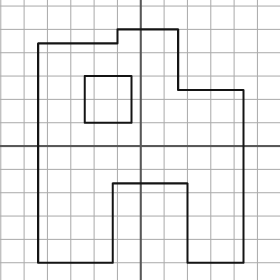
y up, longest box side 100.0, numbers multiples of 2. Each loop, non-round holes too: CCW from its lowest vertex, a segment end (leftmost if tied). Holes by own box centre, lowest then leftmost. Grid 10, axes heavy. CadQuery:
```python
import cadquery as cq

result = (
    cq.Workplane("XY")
    .moveTo(-44.0, -50.0)
    .lineTo(-12.0, -50.0)
    .lineTo(-12.0, -16.0)
    .lineTo(20.0, -16.0)
    .lineTo(20.0, -50.0)
    .lineTo(44.0, -50.0)
    .lineTo(44.0, 24.0)
    .lineTo(16.0, 24.0)
    .lineTo(16.0, 50.0)
    .lineTo(-10.0, 50.0)
    .lineTo(-10.0, 44.0)
    .lineTo(-44.0, 44.0)
    .close()
    .moveTo(-24.0, 10.0)
    .lineTo(-4.0, 10.0)
    .lineTo(-4.0, 30.0)
    .lineTo(-24.0, 30.0)
    .close()
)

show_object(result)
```